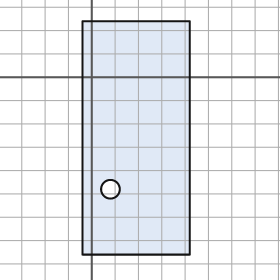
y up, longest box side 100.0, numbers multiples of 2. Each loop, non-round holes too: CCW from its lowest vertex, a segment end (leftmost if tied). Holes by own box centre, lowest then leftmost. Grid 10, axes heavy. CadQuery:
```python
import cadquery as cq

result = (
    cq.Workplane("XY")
    .moveTo(-4.0, -76.0)
    .lineTo(42.0, -76.0)
    .lineTo(42.0, 24.0)
    .lineTo(-4.0, 24.0)
    .close()
    .moveTo(8.0, -48.0)
    .circle(4.0)
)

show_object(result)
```